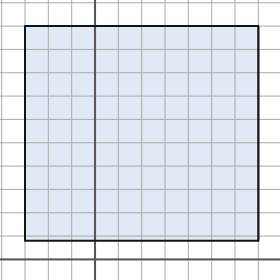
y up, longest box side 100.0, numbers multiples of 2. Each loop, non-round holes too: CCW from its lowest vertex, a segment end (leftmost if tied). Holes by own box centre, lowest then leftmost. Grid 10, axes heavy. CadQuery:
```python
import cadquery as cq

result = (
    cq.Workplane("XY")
    .moveTo(-30.0, 8.0)
    .lineTo(70.0, 8.0)
    .lineTo(70.0, 100.0)
    .lineTo(-30.0, 100.0)
    .close()
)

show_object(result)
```